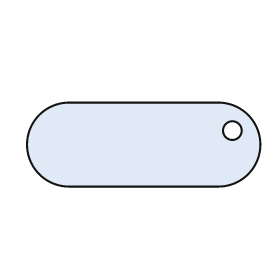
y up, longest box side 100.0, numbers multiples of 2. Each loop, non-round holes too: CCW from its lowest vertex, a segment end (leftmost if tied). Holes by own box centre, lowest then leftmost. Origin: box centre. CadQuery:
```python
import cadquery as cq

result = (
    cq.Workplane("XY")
    .moveTo(-32.0, -18.0)
    .lineTo(32.0, -18.0)
    .threePointArc((50.0, 0.0), (32.0, 18.0))
    .lineTo(-32.0, 18.0)
    .threePointArc((-50.0, 0.0), (-32.0, -18.0))
    .close()
    .moveTo(38.0, 6.0)
    .circle(4.0)
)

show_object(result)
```